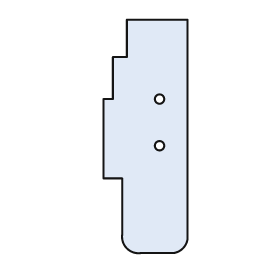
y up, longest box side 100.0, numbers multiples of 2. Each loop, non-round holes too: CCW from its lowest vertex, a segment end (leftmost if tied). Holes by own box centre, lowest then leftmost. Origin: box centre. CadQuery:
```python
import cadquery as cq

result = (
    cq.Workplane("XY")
    .moveTo(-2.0, -50.0)
    .lineTo(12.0, -50.0)
    .threePointArc((16.0, -48.0), (18.0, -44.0))
    .lineTo(18.0, 50.0)
    .lineTo(-8.0, 50.0)
    .lineTo(-8.0, 34.0)
    .lineTo(-14.0, 34.0)
    .lineTo(-14.0, 16.0)
    .lineTo(-18.0, 16.0)
    .lineTo(-18.0, -18.0)
    .lineTo(-10.0, -18.0)
    .lineTo(-10.0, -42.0)
    .threePointArc((-8.0, -48.0), (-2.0, -50.0))
    .close()
    .moveTo(6.0, -4.0)
    .circle(2.0)
    .moveTo(6.0, 16.0)
    .circle(2.0)
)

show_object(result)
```